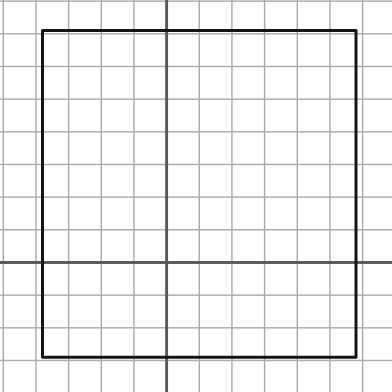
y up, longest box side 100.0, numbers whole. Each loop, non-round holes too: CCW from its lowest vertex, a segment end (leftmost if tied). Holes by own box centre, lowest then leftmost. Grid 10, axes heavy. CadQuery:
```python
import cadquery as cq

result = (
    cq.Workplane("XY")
    .moveTo(-38.0, -29.0)
    .lineTo(58.0, -29.0)
    .lineTo(58.0, 71.0)
    .lineTo(-38.0, 71.0)
    .close()
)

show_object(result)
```